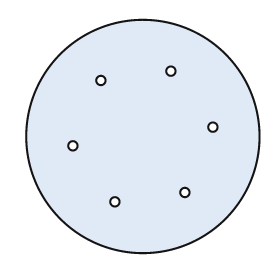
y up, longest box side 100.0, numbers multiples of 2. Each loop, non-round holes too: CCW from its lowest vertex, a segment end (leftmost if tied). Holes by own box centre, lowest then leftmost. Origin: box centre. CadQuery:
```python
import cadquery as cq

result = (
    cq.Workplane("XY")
    .moveTo(0.0, 0.0)
    .circle(50.0)
    .moveTo(-12.0, -28.0)
    .circle(2.0)
    .moveTo(18.0, -24.0)
    .circle(2.0)
    .moveTo(-30.0, -4.0)
    .circle(2.0)
    .moveTo(30.0, 4.0)
    .circle(2.0)
    .moveTo(-18.0, 24.0)
    .circle(2.0)
    .moveTo(12.0, 28.0)
    .circle(2.0)
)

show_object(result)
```